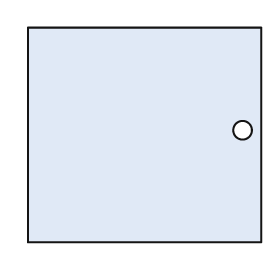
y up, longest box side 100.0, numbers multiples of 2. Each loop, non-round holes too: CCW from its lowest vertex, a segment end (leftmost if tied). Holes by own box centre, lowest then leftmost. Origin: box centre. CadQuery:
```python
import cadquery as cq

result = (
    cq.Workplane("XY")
    .moveTo(-50.0, -46.0)
    .lineTo(50.0, -46.0)
    .lineTo(50.0, 46.0)
    .lineTo(-50.0, 46.0)
    .close()
    .moveTo(42.0, 2.0)
    .circle(4.0)
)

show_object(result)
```